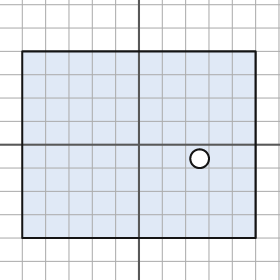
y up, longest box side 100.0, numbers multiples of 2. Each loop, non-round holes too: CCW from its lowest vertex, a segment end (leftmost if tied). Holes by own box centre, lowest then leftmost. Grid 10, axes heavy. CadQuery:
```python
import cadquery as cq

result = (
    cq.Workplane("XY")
    .moveTo(-50.0, -40.0)
    .lineTo(50.0, -40.0)
    .lineTo(50.0, 40.0)
    .lineTo(-50.0, 40.0)
    .close()
    .moveTo(26.0, -6.0)
    .circle(4.0)
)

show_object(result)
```